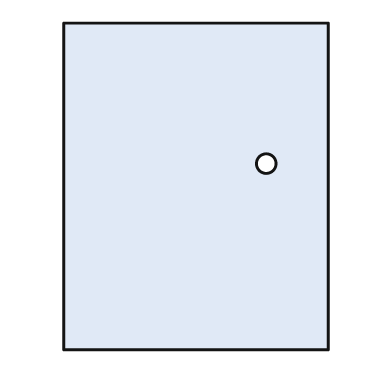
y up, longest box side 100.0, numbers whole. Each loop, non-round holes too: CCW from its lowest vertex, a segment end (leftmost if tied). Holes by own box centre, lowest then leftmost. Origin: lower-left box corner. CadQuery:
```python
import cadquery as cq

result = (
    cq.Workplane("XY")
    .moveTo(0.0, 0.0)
    .lineTo(81.0, 0.0)
    .lineTo(81.0, 100.0)
    .lineTo(0.0, 100.0)
    .close()
    .moveTo(62.0, 57.0)
    .circle(3.0)
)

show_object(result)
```